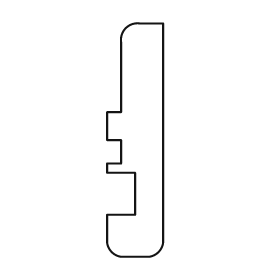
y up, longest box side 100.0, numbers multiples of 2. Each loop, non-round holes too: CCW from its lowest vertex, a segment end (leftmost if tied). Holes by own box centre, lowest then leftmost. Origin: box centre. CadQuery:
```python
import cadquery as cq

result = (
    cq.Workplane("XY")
    .moveTo(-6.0, -50.0)
    .lineTo(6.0, -50.0)
    .threePointArc((10.0, -48.0), (12.0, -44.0))
    .lineTo(12.0, 50.0)
    .lineTo(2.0, 50.0)
    .threePointArc((-4.0, 48.0), (-6.0, 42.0))
    .lineTo(-6.0, 12.0)
    .lineTo(-12.0, 12.0)
    .lineTo(-12.0, 0.0)
    .lineTo(-6.0, 0.0)
    .lineTo(-6.0, -10.0)
    .lineTo(-12.0, -10.0)
    .lineTo(-12.0, -14.0)
    .lineTo(0.0, -14.0)
    .lineTo(0.0, -32.0)
    .lineTo(-12.0, -32.0)
    .lineTo(-12.0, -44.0)
    .threePointArc((-10.0, -48.0), (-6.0, -50.0))
    .close()
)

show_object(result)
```